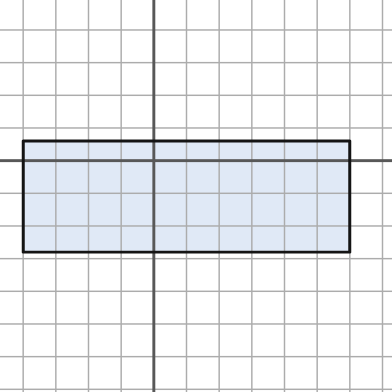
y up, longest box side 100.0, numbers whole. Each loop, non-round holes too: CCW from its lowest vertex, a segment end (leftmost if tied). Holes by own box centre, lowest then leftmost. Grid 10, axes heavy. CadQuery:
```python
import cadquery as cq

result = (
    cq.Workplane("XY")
    .moveTo(-40.0, -28.0)
    .lineTo(60.0, -28.0)
    .lineTo(60.0, 6.0)
    .lineTo(-40.0, 6.0)
    .close()
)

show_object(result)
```